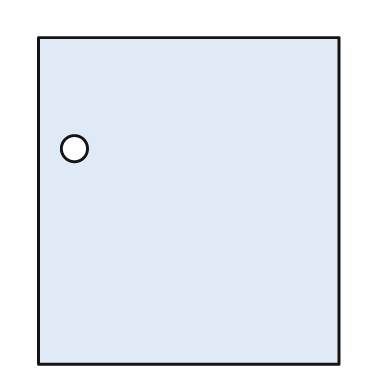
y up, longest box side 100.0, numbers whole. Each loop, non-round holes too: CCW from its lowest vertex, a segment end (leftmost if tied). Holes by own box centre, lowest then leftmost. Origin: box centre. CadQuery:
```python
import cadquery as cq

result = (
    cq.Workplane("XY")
    .moveTo(-46.0, -50.0)
    .lineTo(46.0, -50.0)
    .lineTo(46.0, 50.0)
    .lineTo(-46.0, 50.0)
    .close()
    .moveTo(-35.0, 16.0)
    .circle(4.0)
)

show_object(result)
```